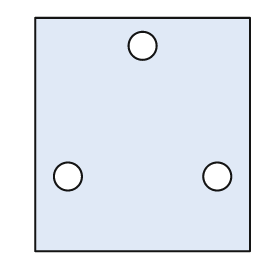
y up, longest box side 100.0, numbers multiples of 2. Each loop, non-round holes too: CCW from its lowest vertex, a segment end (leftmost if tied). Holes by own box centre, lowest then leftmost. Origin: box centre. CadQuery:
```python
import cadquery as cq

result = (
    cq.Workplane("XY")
    .moveTo(-46.0, -50.0)
    .lineTo(46.0, -50.0)
    .lineTo(46.0, 50.0)
    .lineTo(-46.0, 50.0)
    .close()
    .moveTo(-32.0, -18.0)
    .circle(6.0)
    .moveTo(32.0, -18.0)
    .circle(6.0)
    .moveTo(0.0, 38.0)
    .circle(6.0)
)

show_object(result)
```